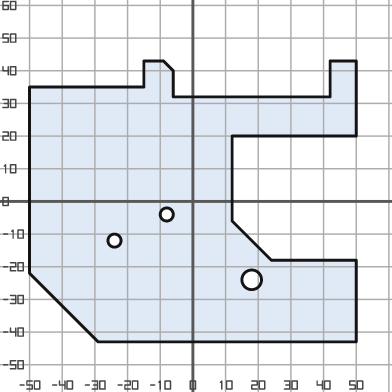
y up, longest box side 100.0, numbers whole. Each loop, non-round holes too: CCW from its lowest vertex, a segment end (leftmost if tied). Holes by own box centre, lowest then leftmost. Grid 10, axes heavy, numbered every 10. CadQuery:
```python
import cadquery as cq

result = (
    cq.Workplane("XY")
    .moveTo(-29.0, -43.0)
    .lineTo(50.0, -43.0)
    .lineTo(50.0, -18.0)
    .lineTo(24.0, -18.0)
    .lineTo(12.0, -6.0)
    .lineTo(12.0, 20.0)
    .lineTo(50.0, 20.0)
    .lineTo(50.0, 43.0)
    .lineTo(42.0, 43.0)
    .lineTo(42.0, 32.0)
    .lineTo(-6.0, 32.0)
    .lineTo(-6.0, 40.0)
    .lineTo(-9.0, 43.0)
    .lineTo(-15.0, 43.0)
    .lineTo(-15.0, 35.0)
    .lineTo(-50.0, 35.0)
    .lineTo(-50.0, -22.0)
    .close()
    .moveTo(18.0, -24.0)
    .circle(3.0)
    .moveTo(-24.0, -12.0)
    .circle(2.0)
    .moveTo(-8.0, -4.0)
    .circle(2.0)
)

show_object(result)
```